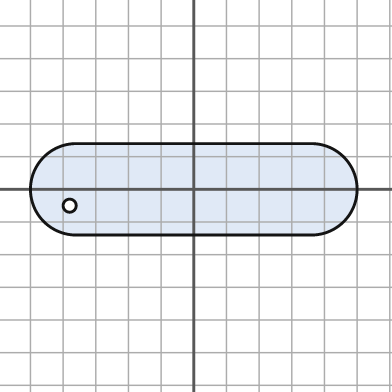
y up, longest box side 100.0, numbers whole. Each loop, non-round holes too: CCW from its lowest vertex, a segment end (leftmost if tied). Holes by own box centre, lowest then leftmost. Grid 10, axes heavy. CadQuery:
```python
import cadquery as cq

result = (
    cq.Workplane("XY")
    .moveTo(-36.0, -14.0)
    .lineTo(36.0, -14.0)
    .threePointArc((50.0, 0.0), (36.0, 14.0))
    .lineTo(-36.0, 14.0)
    .threePointArc((-50.0, 0.0), (-36.0, -14.0))
    .close()
    .moveTo(-38.0, -5.0)
    .circle(2.0)
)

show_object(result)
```